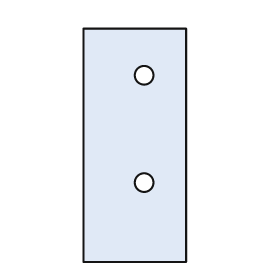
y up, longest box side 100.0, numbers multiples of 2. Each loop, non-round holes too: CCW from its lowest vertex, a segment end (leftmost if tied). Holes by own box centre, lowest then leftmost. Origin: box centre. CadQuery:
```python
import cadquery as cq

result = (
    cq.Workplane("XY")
    .moveTo(-22.0, -50.0)
    .lineTo(22.0, -50.0)
    .lineTo(22.0, 50.0)
    .lineTo(-22.0, 50.0)
    .close()
    .moveTo(4.0, -16.0)
    .circle(4.0)
    .moveTo(4.0, 30.0)
    .circle(4.0)
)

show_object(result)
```